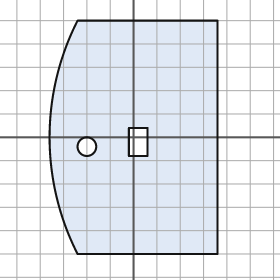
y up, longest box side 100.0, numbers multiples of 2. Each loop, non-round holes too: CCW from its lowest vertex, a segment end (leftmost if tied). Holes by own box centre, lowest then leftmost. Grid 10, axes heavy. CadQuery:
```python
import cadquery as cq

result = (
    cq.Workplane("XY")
    .moveTo(-24.0, -50.0)
    .lineTo(36.0, -50.0)
    .lineTo(36.0, 50.0)
    .lineTo(-24.0, 50.0)
    .threePointArc((-36.0, 0.0), (-24.0, -50.0))
    .close()
    .moveTo(-20.0, -4.0)
    .circle(4.0)
    .moveTo(-2.0, -8.0)
    .lineTo(6.0, -8.0)
    .lineTo(6.0, 4.0)
    .lineTo(-2.0, 4.0)
    .close()
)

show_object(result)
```